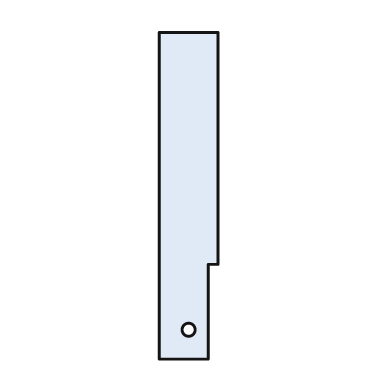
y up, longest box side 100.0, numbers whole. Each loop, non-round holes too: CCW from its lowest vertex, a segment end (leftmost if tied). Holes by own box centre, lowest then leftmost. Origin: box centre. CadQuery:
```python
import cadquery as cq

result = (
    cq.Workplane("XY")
    .moveTo(-9.0, -50.0)
    .lineTo(6.0, -50.0)
    .lineTo(6.0, -21.0)
    .lineTo(9.0, -21.0)
    .lineTo(9.0, 50.0)
    .lineTo(-9.0, 50.0)
    .close()
    .moveTo(0.0, -41.0)
    .circle(2.0)
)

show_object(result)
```